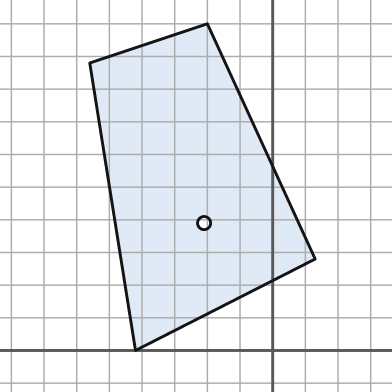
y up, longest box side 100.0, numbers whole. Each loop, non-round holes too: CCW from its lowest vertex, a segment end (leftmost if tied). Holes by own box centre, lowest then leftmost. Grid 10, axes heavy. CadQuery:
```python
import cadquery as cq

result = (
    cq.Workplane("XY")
    .moveTo(-42.0, 0.0)
    .lineTo(13.0, 28.0)
    .lineTo(-20.0, 100.0)
    .lineTo(-56.0, 88.0)
    .close()
    .moveTo(-21.0, 39.0)
    .circle(2.0)
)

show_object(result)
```